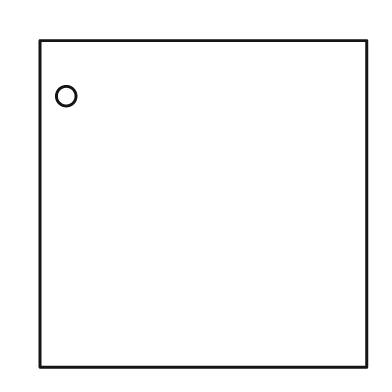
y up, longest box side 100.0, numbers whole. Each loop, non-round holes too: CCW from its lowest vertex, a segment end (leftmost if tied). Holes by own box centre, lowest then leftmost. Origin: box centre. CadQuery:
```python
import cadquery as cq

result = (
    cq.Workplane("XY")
    .moveTo(-50.0, -50.0)
    .lineTo(50.0, -50.0)
    .lineTo(50.0, 50.0)
    .lineTo(-50.0, 50.0)
    .close()
    .moveTo(-42.0, 33.0)
    .circle(3.0)
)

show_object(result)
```